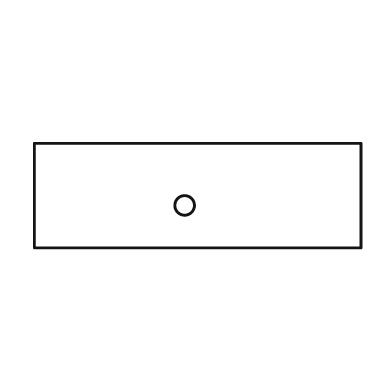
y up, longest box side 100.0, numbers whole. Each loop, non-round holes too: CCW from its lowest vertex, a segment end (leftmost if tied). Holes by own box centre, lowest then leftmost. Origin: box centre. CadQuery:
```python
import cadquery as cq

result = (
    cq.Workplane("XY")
    .moveTo(-50.0, -16.0)
    .lineTo(50.0, -16.0)
    .lineTo(50.0, 16.0)
    .lineTo(-50.0, 16.0)
    .close()
    .moveTo(-4.0, -3.0)
    .circle(3.0)
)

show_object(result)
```